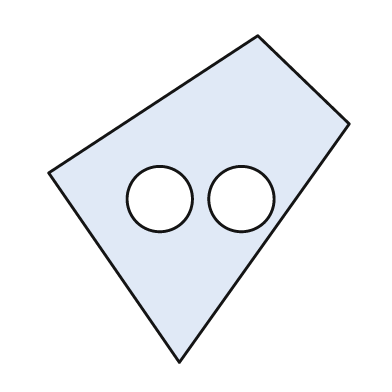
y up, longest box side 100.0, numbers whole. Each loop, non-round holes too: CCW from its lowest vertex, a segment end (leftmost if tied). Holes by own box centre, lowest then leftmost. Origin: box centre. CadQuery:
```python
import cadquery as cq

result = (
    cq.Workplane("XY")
    .moveTo(-6.0, -50.0)
    .lineTo(46.0, 23.0)
    .lineTo(18.0, 50.0)
    .lineTo(-46.0, 8.0)
    .close()
    .moveTo(-12.0, 0.0)
    .circle(10.0)
    .moveTo(13.0, 0.0)
    .circle(10.0)
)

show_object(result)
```